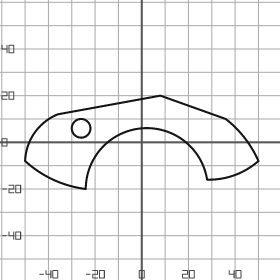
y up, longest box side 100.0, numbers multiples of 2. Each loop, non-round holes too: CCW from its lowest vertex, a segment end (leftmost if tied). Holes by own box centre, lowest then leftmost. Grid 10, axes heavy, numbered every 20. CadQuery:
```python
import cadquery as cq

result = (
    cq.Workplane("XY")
    .moveTo(-24.0, -20.0)
    .threePointArc((0.0, 6.0), (28.0, -16.0))
    .threePointArc((40.0, -14.0), (50.0, -8.0))
    .threePointArc((44.0, 2.0), (36.0, 10.0))
    .lineTo(8.0, 20.0)
    .lineTo(-36.0, 12.0)
    .threePointArc((-46.0, 4.0), (-50.0, -8.0))
    .threePointArc((-38.0, -16.0), (-24.0, -20.0))
    .close()
    .moveTo(-26.0, 6.0)
    .circle(4.0)
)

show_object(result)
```